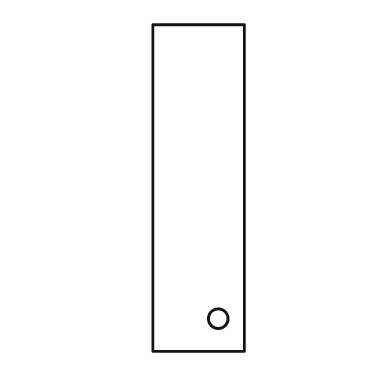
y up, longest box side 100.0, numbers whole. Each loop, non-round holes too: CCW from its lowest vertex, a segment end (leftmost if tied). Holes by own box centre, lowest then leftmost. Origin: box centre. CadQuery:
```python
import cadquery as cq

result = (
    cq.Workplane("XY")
    .moveTo(-14.0, -50.0)
    .lineTo(14.0, -50.0)
    .lineTo(14.0, 50.0)
    .lineTo(-14.0, 50.0)
    .close()
    .moveTo(6.0, -40.0)
    .circle(3.0)
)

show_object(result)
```